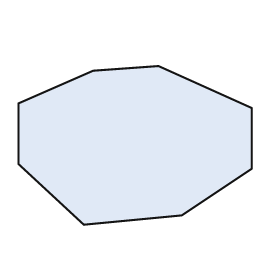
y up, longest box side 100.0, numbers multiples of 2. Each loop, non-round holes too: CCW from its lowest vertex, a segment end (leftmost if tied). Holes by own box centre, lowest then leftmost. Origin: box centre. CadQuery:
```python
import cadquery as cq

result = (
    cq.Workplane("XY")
    .moveTo(-22.0, -34.0)
    .lineTo(20.0, -30.0)
    .lineTo(50.0, -10.0)
    .lineTo(50.0, 16.0)
    .lineTo(10.0, 34.0)
    .lineTo(-18.0, 32.0)
    .lineTo(-50.0, 18.0)
    .lineTo(-50.0, -8.0)
    .close()
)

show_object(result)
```